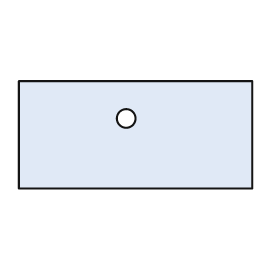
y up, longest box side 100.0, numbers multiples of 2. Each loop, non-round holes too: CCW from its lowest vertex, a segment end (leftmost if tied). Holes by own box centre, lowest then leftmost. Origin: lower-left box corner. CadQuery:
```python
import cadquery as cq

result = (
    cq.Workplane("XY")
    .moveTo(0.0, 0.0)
    .lineTo(100.0, 0.0)
    .lineTo(100.0, 46.0)
    .lineTo(0.0, 46.0)
    .close()
    .moveTo(46.0, 30.0)
    .circle(4.0)
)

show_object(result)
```